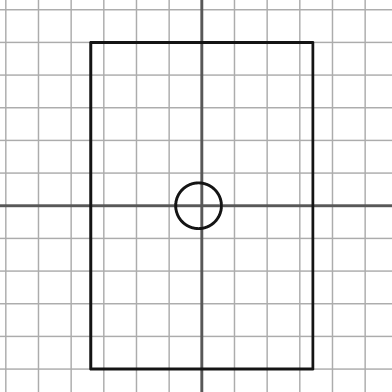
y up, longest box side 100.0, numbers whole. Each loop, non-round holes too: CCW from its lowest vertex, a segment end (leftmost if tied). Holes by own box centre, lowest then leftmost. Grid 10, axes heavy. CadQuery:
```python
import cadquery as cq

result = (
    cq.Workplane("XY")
    .moveTo(-34.0, -50.0)
    .lineTo(34.0, -50.0)
    .lineTo(34.0, 50.0)
    .lineTo(-34.0, 50.0)
    .close()
    .moveTo(-1.0, 0.0)
    .circle(7.0)
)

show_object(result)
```